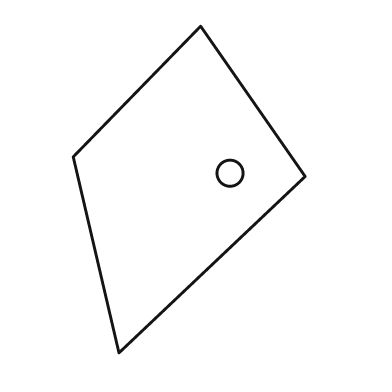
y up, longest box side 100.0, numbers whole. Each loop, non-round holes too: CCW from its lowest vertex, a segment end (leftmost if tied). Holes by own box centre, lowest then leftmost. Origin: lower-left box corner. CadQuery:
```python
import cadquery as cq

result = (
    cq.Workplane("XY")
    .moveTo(14.0, 0.0)
    .lineTo(71.0, 54.0)
    .lineTo(39.0, 100.0)
    .lineTo(0.0, 60.0)
    .close()
    .moveTo(48.0, 55.0)
    .circle(4.0)
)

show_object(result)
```